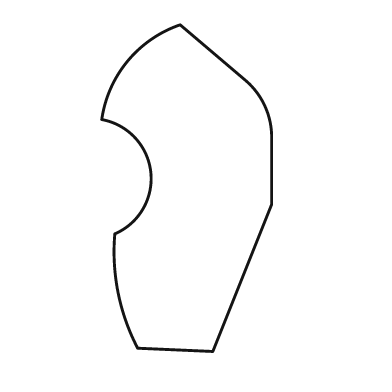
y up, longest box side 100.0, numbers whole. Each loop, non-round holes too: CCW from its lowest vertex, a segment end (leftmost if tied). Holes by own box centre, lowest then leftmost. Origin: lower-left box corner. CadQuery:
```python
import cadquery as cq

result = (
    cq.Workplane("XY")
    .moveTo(34.0, 0.0)
    .lineTo(52.0, 45.0)
    .lineTo(52.0, 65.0)
    .threePointArc((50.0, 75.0), (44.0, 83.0))
    .lineTo(24.0, 100.0)
    .threePointArc((8.0, 89.0), (0.0, 71.0))
    .threePointArc((15.0, 55.0), (4.0, 36.0))
    .threePointArc((5.0, 18.0), (11.0, 1.0))
    .close()
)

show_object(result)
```